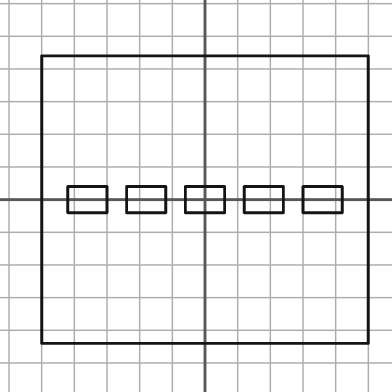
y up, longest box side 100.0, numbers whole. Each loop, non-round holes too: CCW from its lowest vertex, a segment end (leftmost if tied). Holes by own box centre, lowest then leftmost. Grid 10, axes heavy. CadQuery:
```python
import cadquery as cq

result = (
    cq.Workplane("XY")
    .moveTo(-50.0, -44.0)
    .lineTo(50.0, -44.0)
    .lineTo(50.0, 44.0)
    .lineTo(-50.0, 44.0)
    .close()
    .moveTo(-42.0, -4.0)
    .lineTo(-30.0, -4.0)
    .lineTo(-30.0, 4.0)
    .lineTo(-42.0, 4.0)
    .close()
    .moveTo(-24.0, -4.0)
    .lineTo(-12.0, -4.0)
    .lineTo(-12.0, 4.0)
    .lineTo(-24.0, 4.0)
    .close()
    .moveTo(-6.0, -4.0)
    .lineTo(6.0, -4.0)
    .lineTo(6.0, 4.0)
    .lineTo(-6.0, 4.0)
    .close()
    .moveTo(12.0, -4.0)
    .lineTo(24.0, -4.0)
    .lineTo(24.0, 4.0)
    .lineTo(12.0, 4.0)
    .close()
    .moveTo(30.0, -4.0)
    .lineTo(42.0, -4.0)
    .lineTo(42.0, 4.0)
    .lineTo(30.0, 4.0)
    .close()
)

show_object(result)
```